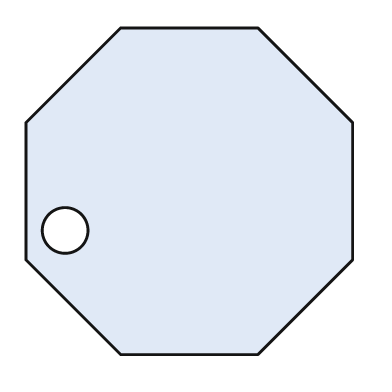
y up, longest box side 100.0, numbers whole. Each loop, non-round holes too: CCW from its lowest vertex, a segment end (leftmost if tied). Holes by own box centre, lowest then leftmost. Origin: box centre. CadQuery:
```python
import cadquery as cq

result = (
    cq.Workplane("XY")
    .moveTo(-21.0, -50.0)
    .lineTo(21.0, -50.0)
    .lineTo(50.0, -21.0)
    .lineTo(50.0, 21.0)
    .lineTo(21.0, 50.0)
    .lineTo(-21.0, 50.0)
    .lineTo(-50.0, 21.0)
    .lineTo(-50.0, -21.0)
    .close()
    .moveTo(-38.0, -12.0)
    .circle(7.0)
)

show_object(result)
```